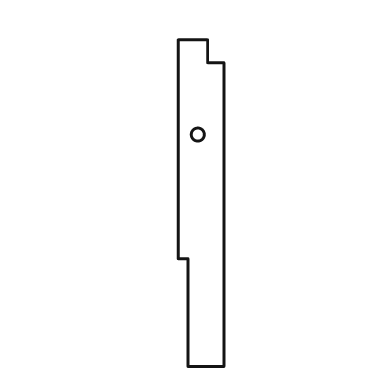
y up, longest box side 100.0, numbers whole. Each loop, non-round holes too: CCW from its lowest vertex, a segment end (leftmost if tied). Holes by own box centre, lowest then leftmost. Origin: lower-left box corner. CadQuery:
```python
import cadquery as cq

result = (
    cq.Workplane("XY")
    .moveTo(3.0, 0.0)
    .lineTo(14.0, 0.0)
    .lineTo(14.0, 93.0)
    .lineTo(9.0, 93.0)
    .lineTo(9.0, 100.0)
    .lineTo(0.0, 100.0)
    .lineTo(0.0, 33.0)
    .lineTo(3.0, 33.0)
    .close()
    .moveTo(6.0, 71.0)
    .circle(2.0)
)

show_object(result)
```